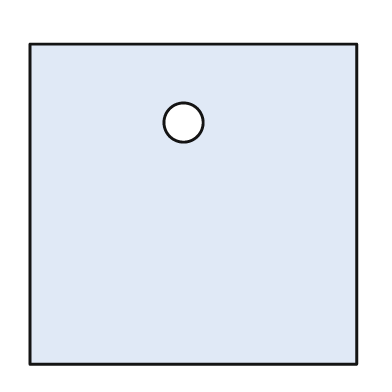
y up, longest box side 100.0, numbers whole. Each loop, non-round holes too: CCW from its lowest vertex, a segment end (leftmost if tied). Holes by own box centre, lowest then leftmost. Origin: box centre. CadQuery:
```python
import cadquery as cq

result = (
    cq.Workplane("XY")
    .moveTo(-50.0, -49.0)
    .lineTo(50.0, -49.0)
    .lineTo(50.0, 49.0)
    .lineTo(-50.0, 49.0)
    .close()
    .moveTo(-3.0, 25.0)
    .circle(6.0)
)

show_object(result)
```